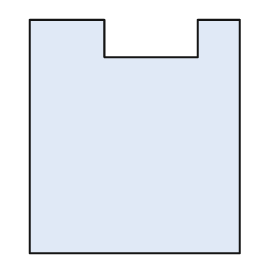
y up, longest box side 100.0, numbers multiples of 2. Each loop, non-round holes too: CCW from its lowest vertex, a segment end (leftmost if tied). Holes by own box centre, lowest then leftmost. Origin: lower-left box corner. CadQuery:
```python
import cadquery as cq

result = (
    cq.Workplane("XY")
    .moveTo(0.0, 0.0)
    .lineTo(90.0, 0.0)
    .lineTo(90.0, 100.0)
    .lineTo(72.0, 100.0)
    .lineTo(72.0, 84.0)
    .lineTo(32.0, 84.0)
    .lineTo(32.0, 100.0)
    .lineTo(0.0, 100.0)
    .close()
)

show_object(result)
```